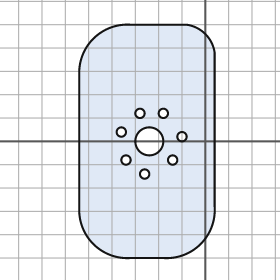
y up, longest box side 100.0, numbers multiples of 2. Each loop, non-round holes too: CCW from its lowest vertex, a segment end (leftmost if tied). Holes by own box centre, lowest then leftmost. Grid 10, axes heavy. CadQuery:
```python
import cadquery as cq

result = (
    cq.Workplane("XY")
    .moveTo(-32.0, -50.0)
    .lineTo(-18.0, -50.0)
    .threePointArc((-2.0, -44.0), (4.0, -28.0))
    .lineTo(4.0, 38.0)
    .threePointArc((0.0, 46.0), (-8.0, 50.0))
    .lineTo(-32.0, 50.0)
    .threePointArc((-48.0, 44.0), (-54.0, 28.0))
    .lineTo(-54.0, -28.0)
    .threePointArc((-48.0, -44.0), (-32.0, -50.0))
    .close()
    .moveTo(-26.0, -14.0)
    .circle(2.0)
    .moveTo(-34.0, -8.0)
    .circle(2.0)
    .moveTo(-14.0, -8.0)
    .circle(2.0)
    .moveTo(-24.0, 0.0)
    .circle(6.0)
    .moveTo(-10.0, 2.0)
    .circle(2.0)
    .moveTo(-36.0, 4.0)
    .circle(2.0)
    .moveTo(-28.0, 12.0)
    .circle(2.0)
    .moveTo(-18.0, 12.0)
    .circle(2.0)
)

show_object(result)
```